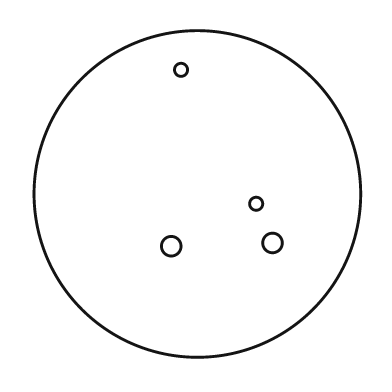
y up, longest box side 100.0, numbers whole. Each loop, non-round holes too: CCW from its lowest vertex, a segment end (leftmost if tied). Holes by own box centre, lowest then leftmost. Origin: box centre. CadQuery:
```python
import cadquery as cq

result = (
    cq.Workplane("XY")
    .moveTo(0.0, 0.0)
    .circle(50.0)
    .moveTo(-8.0, -16.0)
    .circle(3.0)
    .moveTo(23.0, -15.0)
    .circle(3.0)
    .moveTo(18.0, -3.0)
    .circle(2.0)
    .moveTo(-5.0, 38.0)
    .circle(2.0)
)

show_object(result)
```